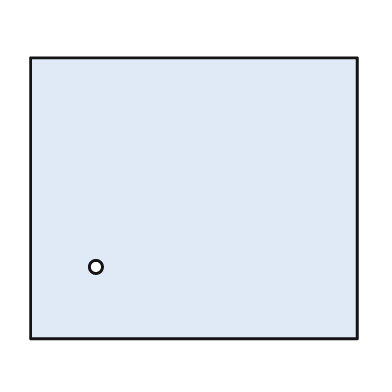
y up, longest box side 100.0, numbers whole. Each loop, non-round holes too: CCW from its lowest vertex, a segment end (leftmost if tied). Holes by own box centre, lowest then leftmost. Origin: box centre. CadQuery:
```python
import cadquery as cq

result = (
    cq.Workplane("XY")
    .moveTo(-50.0, -43.0)
    .lineTo(50.0, -43.0)
    .lineTo(50.0, 43.0)
    .lineTo(-50.0, 43.0)
    .close()
    .moveTo(-30.0, -21.0)
    .circle(2.0)
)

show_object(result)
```